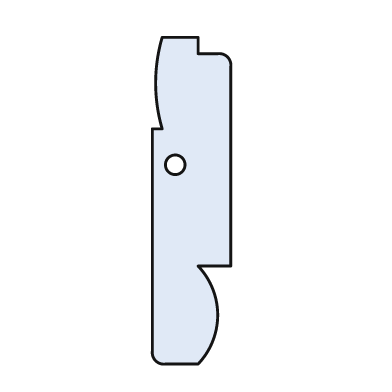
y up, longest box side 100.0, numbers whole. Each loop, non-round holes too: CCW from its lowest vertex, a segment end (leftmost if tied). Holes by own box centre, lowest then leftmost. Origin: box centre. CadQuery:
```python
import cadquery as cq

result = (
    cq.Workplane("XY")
    .moveTo(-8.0, -50.0)
    .lineTo(2.0, -50.0)
    .threePointArc((8.0, -35.0), (2.0, -20.0))
    .lineTo(12.0, -20.0)
    .lineTo(12.0, 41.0)
    .threePointArc((11.0, 44.0), (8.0, 45.0))
    .lineTo(2.0, 45.0)
    .lineTo(2.0, 50.0)
    .lineTo(-9.0, 50.0)
    .threePointArc((-11.0, 36.0), (-9.0, 22.0))
    .lineTo(-12.0, 22.0)
    .lineTo(-12.0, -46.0)
    .threePointArc((-11.0, -49.0), (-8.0, -50.0))
    .close()
    .moveTo(-5.0, 11.0)
    .circle(3.0)
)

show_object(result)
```